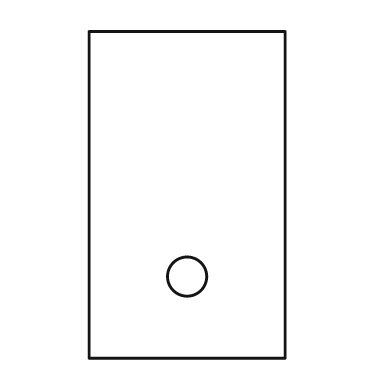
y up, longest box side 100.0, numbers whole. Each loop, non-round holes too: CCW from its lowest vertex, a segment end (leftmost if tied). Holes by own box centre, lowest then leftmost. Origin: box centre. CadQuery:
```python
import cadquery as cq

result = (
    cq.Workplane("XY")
    .moveTo(-30.0, -50.0)
    .lineTo(30.0, -50.0)
    .lineTo(30.0, 50.0)
    .lineTo(-30.0, 50.0)
    .close()
    .moveTo(0.0, -25.0)
    .circle(6.0)
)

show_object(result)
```